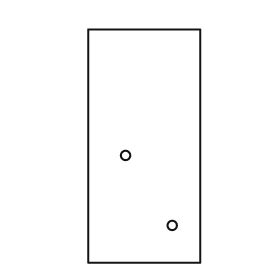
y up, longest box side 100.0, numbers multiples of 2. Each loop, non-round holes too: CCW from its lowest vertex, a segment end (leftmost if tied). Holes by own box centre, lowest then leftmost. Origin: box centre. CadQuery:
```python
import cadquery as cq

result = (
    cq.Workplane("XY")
    .moveTo(-24.0, -50.0)
    .lineTo(24.0, -50.0)
    .lineTo(24.0, 50.0)
    .lineTo(-24.0, 50.0)
    .close()
    .moveTo(12.0, -34.0)
    .circle(2.0)
    .moveTo(-8.0, -4.0)
    .circle(2.0)
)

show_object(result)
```